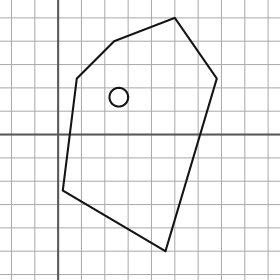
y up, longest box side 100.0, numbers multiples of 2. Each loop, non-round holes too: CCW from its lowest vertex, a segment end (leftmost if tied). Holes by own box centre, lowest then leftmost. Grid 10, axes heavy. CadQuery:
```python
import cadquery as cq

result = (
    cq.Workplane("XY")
    .moveTo(46.0, -50.0)
    .lineTo(68.0, 24.0)
    .lineTo(50.0, 50.0)
    .lineTo(24.0, 40.0)
    .lineTo(8.0, 24.0)
    .lineTo(2.0, -24.0)
    .close()
    .moveTo(26.0, 16.0)
    .circle(4.0)
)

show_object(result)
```